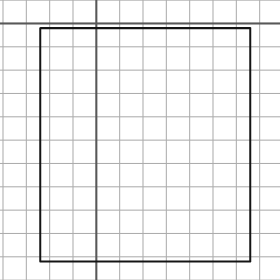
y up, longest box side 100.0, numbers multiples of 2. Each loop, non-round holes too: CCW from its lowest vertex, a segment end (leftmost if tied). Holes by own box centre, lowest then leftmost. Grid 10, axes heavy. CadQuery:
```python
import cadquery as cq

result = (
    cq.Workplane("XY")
    .moveTo(-24.0, -102.0)
    .lineTo(66.0, -102.0)
    .lineTo(66.0, -2.0)
    .lineTo(-24.0, -2.0)
    .close()
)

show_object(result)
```